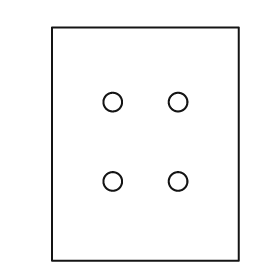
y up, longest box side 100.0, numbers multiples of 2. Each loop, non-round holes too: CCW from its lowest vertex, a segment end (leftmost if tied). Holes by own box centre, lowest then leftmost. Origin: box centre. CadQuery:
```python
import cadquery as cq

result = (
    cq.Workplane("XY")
    .moveTo(-40.0, -50.0)
    .lineTo(40.0, -50.0)
    .lineTo(40.0, 50.0)
    .lineTo(-40.0, 50.0)
    .close()
    .moveTo(-14.0, -16.0)
    .circle(4.0)
    .moveTo(14.0, -16.0)
    .circle(4.0)
    .moveTo(-14.0, 18.0)
    .circle(4.0)
    .moveTo(14.0, 18.0)
    .circle(4.0)
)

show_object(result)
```